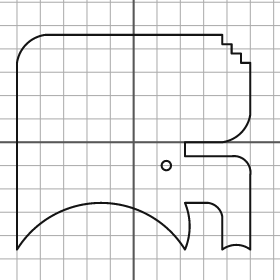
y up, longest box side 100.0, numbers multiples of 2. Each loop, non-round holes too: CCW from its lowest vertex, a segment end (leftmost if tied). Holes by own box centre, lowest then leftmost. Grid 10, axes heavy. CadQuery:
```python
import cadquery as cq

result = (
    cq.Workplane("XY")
    .moveTo(-50.0, -46.0)
    .threePointArc((-14.0, -26.0), (22.0, -46.0))
    .threePointArc((24.0, -36.0), (22.0, -26.0))
    .lineTo(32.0, -26.0)
    .threePointArc((36.0, -28.0), (38.0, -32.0))
    .lineTo(38.0, -46.0)
    .threePointArc((44.0, -44.0), (50.0, -46.0))
    .lineTo(50.0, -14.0)
    .threePointArc((48.0, -8.0), (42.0, -6.0))
    .lineTo(22.0, -6.0)
    .lineTo(22.0, 0.0)
    .lineTo(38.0, 0.0)
    .threePointArc((46.0, 4.0), (50.0, 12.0))
    .lineTo(50.0, 34.0)
    .lineTo(46.0, 34.0)
    .lineTo(46.0, 38.0)
    .lineTo(42.0, 38.0)
    .lineTo(42.0, 42.0)
    .lineTo(38.0, 42.0)
    .lineTo(38.0, 46.0)
    .lineTo(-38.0, 46.0)
    .threePointArc((-46.0, 42.0), (-50.0, 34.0))
    .close()
    .moveTo(14.0, -10.0)
    .circle(2.0)
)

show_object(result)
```